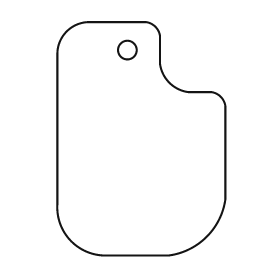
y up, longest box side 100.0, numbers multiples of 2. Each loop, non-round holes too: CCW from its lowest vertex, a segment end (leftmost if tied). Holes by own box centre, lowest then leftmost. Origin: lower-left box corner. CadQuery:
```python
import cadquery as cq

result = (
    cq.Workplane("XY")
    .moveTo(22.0, 0.0)
    .lineTo(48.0, 0.0)
    .threePointArc((64.0, 8.0), (72.0, 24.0))
    .lineTo(72.0, 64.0)
    .threePointArc((70.0, 68.0), (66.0, 70.0))
    .lineTo(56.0, 70.0)
    .threePointArc((48.0, 74.0), (44.0, 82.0))
    .lineTo(44.0, 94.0)
    .threePointArc((42.0, 98.0), (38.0, 100.0))
    .lineTo(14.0, 100.0)
    .threePointArc((4.0, 96.0), (0.0, 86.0))
    .lineTo(0.0, 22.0)
    .threePointArc((6.0, 6.0), (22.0, 0.0))
    .close()
    .moveTo(30.0, 88.0)
    .circle(4.0)
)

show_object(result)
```